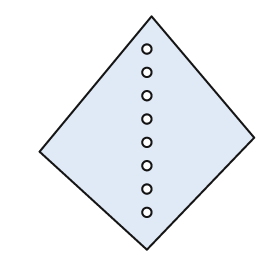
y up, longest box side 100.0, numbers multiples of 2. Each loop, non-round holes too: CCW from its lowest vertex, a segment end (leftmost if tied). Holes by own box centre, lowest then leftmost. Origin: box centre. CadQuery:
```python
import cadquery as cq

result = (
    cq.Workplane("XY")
    .moveTo(0.0, -50.0)
    .lineTo(46.0, -2.0)
    .lineTo(2.0, 50.0)
    .lineTo(-46.0, -8.0)
    .close()
    .moveTo(0.0, -34.0)
    .circle(2.0)
    .moveTo(0.0, -24.0)
    .circle(2.0)
    .moveTo(0.0, -14.0)
    .circle(2.0)
    .moveTo(0.0, -4.0)
    .circle(2.0)
    .moveTo(0.0, 6.0)
    .circle(2.0)
    .moveTo(0.0, 16.0)
    .circle(2.0)
    .moveTo(0.0, 26.0)
    .circle(2.0)
    .moveTo(0.0, 36.0)
    .circle(2.0)
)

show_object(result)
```